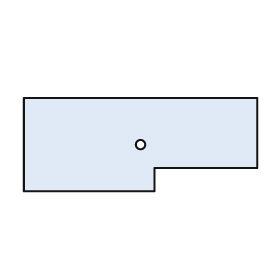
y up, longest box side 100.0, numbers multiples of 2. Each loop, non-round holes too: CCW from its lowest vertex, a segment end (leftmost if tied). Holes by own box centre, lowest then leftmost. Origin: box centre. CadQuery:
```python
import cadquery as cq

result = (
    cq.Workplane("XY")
    .moveTo(-50.0, -20.0)
    .lineTo(6.0, -20.0)
    .lineTo(6.0, -10.0)
    .lineTo(50.0, -10.0)
    .lineTo(50.0, 20.0)
    .lineTo(-50.0, 20.0)
    .close()
    .moveTo(0.0, 0.0)
    .circle(2.0)
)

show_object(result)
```